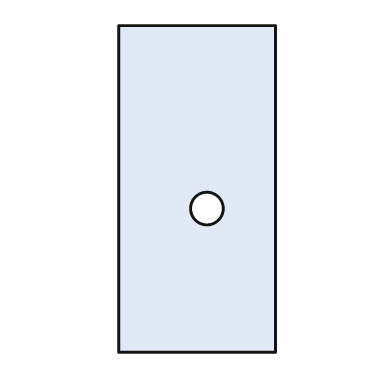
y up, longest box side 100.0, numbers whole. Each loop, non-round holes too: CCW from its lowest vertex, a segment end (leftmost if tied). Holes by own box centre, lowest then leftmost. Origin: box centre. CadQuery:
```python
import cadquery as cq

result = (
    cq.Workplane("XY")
    .moveTo(-24.0, -50.0)
    .lineTo(24.0, -50.0)
    .lineTo(24.0, 50.0)
    .lineTo(-24.0, 50.0)
    .close()
    .moveTo(3.0, -6.0)
    .circle(5.0)
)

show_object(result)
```